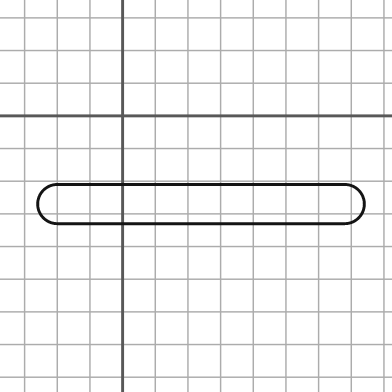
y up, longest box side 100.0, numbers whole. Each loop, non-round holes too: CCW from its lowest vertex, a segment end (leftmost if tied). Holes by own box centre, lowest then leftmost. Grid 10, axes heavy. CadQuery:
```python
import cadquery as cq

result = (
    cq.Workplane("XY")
    .moveTo(-20.0, -33.0)
    .lineTo(68.0, -33.0)
    .threePointArc((74.0, -27.0), (68.0, -21.0))
    .lineTo(-20.0, -21.0)
    .threePointArc((-26.0, -27.0), (-20.0, -33.0))
    .close()
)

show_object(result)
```